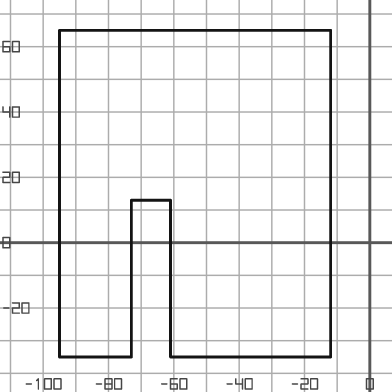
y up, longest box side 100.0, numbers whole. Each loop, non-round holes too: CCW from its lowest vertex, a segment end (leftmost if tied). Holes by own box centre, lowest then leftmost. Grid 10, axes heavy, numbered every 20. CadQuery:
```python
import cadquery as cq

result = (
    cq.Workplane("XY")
    .moveTo(-95.0, -35.0)
    .lineTo(-73.0, -35.0)
    .lineTo(-73.0, 13.0)
    .lineTo(-61.0, 13.0)
    .lineTo(-61.0, -35.0)
    .lineTo(-12.0, -35.0)
    .lineTo(-12.0, 65.0)
    .lineTo(-95.0, 65.0)
    .close()
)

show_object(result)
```